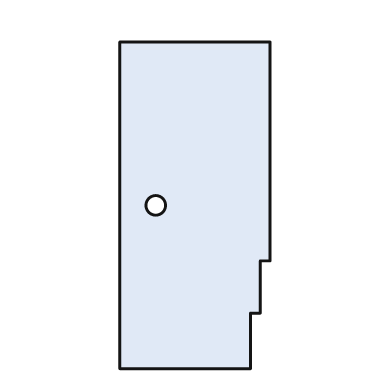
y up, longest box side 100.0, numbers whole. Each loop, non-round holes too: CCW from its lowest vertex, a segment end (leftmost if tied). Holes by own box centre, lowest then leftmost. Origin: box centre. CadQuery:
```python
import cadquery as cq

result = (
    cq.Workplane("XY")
    .moveTo(-23.0, -50.0)
    .lineTo(17.0, -50.0)
    .lineTo(17.0, -33.0)
    .lineTo(20.0, -33.0)
    .lineTo(20.0, -17.0)
    .lineTo(23.0, -17.0)
    .lineTo(23.0, 50.0)
    .lineTo(-23.0, 50.0)
    .close()
    .moveTo(-12.0, 0.0)
    .circle(3.0)
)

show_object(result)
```